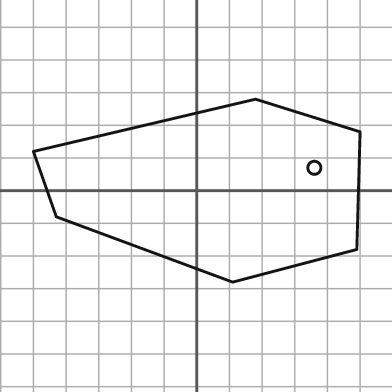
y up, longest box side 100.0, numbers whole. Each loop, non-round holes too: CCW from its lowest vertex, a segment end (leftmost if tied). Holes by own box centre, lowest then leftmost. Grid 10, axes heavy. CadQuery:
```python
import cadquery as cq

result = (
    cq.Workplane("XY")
    .moveTo(11.0, -28.0)
    .lineTo(49.0, -18.0)
    .lineTo(50.0, 18.0)
    .lineTo(18.0, 28.0)
    .lineTo(-50.0, 12.0)
    .lineTo(-43.0, -8.0)
    .close()
    .moveTo(36.0, 7.0)
    .circle(2.0)
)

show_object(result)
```